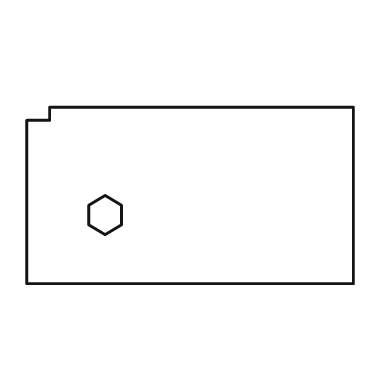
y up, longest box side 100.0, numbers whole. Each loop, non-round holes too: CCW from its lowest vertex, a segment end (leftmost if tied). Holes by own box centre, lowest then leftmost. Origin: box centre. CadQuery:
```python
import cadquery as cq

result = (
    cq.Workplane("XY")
    .moveTo(-50.0, -27.0)
    .lineTo(50.0, -27.0)
    .lineTo(50.0, 27.0)
    .lineTo(-43.0, 27.0)
    .lineTo(-43.0, 23.0)
    .lineTo(-50.0, 23.0)
    .close()
    .moveTo(-26.0, -12.0)
    .lineTo(-21.0, -9.0)
    .lineTo(-21.0, -3.0)
    .lineTo(-26.0, 0.0)
    .lineTo(-31.0, -3.0)
    .lineTo(-31.0, -9.0)
    .close()
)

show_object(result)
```